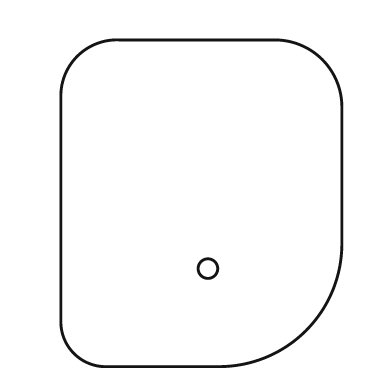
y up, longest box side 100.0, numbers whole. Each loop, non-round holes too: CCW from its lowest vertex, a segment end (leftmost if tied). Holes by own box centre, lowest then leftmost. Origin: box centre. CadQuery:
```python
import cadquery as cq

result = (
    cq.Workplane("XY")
    .moveTo(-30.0, -50.0)
    .lineTo(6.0, -50.0)
    .threePointArc((32.0, -39.0), (43.0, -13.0))
    .lineTo(43.0, 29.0)
    .threePointArc((37.0, 44.0), (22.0, 50.0))
    .lineTo(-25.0, 50.0)
    .threePointArc((-38.0, 45.0), (-43.0, 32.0))
    .lineTo(-43.0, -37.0)
    .threePointArc((-39.0, -46.0), (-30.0, -50.0))
    .close()
    .moveTo(2.0, -20.0)
    .circle(3.0)
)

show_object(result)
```